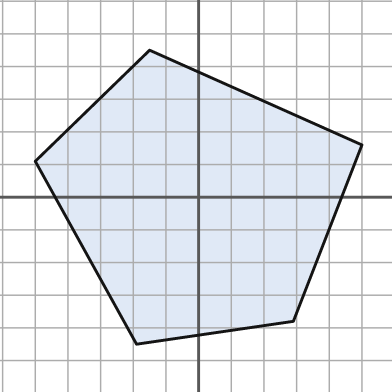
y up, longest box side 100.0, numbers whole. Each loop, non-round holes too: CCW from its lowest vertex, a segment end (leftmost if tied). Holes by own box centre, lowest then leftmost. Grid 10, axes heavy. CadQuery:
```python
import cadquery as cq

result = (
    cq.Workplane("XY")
    .moveTo(-19.0, -45.0)
    .lineTo(29.0, -38.0)
    .lineTo(50.0, 16.0)
    .lineTo(-15.0, 45.0)
    .lineTo(-50.0, 11.0)
    .close()
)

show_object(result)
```